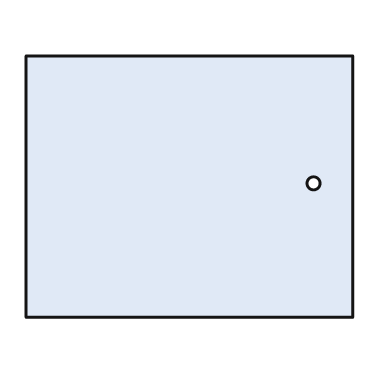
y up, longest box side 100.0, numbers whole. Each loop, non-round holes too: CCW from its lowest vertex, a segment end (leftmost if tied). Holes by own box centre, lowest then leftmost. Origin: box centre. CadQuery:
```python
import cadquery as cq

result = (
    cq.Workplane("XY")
    .moveTo(-50.0, -40.0)
    .lineTo(50.0, -40.0)
    .lineTo(50.0, 40.0)
    .lineTo(-50.0, 40.0)
    .close()
    .moveTo(38.0, 1.0)
    .circle(2.0)
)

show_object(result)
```